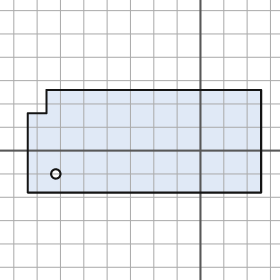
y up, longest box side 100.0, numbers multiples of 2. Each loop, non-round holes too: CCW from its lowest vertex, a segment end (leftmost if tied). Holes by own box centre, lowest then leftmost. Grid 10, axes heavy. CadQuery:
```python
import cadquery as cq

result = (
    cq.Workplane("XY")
    .moveTo(-74.0, -18.0)
    .lineTo(26.0, -18.0)
    .lineTo(26.0, 26.0)
    .lineTo(-66.0, 26.0)
    .lineTo(-66.0, 16.0)
    .lineTo(-74.0, 16.0)
    .close()
    .moveTo(-62.0, -10.0)
    .circle(2.0)
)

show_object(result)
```